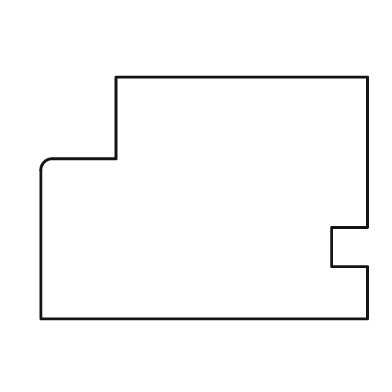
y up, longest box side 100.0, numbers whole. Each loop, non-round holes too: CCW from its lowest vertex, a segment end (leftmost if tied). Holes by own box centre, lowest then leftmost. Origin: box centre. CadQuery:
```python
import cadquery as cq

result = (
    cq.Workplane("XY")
    .moveTo(-50.0, -37.0)
    .lineTo(50.0, -37.0)
    .lineTo(50.0, -21.0)
    .lineTo(39.0, -21.0)
    .lineTo(39.0, -9.0)
    .lineTo(50.0, -9.0)
    .lineTo(50.0, 37.0)
    .lineTo(-27.0, 37.0)
    .lineTo(-27.0, 12.0)
    .lineTo(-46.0, 12.0)
    .threePointArc((-49.0, 11.0), (-50.0, 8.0))
    .close()
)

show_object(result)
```